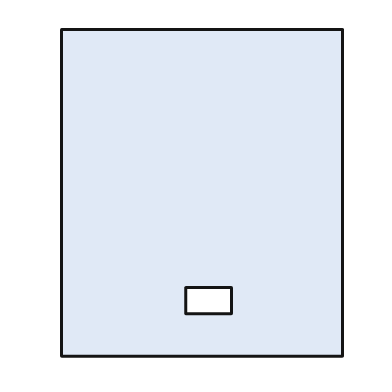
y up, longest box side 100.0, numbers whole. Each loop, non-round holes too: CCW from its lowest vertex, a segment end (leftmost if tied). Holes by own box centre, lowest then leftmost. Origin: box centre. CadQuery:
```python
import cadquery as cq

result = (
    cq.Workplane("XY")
    .moveTo(-43.0, -50.0)
    .lineTo(43.0, -50.0)
    .lineTo(43.0, 50.0)
    .lineTo(-43.0, 50.0)
    .close()
    .moveTo(-5.0, -37.0)
    .lineTo(9.0, -37.0)
    .lineTo(9.0, -29.0)
    .lineTo(-5.0, -29.0)
    .close()
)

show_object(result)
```